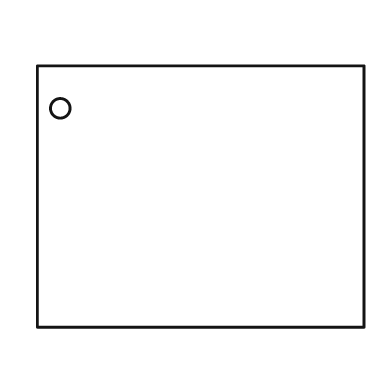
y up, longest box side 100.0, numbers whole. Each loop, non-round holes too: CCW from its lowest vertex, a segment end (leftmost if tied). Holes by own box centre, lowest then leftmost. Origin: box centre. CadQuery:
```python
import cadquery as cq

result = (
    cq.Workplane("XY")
    .moveTo(-50.0, -40.0)
    .lineTo(50.0, -40.0)
    .lineTo(50.0, 40.0)
    .lineTo(-50.0, 40.0)
    .close()
    .moveTo(-43.0, 27.0)
    .circle(3.0)
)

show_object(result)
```